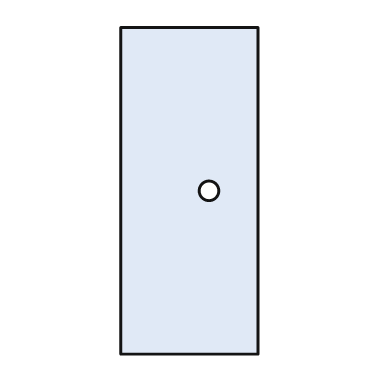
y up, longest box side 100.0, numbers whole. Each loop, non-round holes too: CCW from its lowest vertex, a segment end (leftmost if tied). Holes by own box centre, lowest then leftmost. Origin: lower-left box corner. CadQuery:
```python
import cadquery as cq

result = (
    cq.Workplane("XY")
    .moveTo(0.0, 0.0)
    .lineTo(42.0, 0.0)
    .lineTo(42.0, 100.0)
    .lineTo(0.0, 100.0)
    .close()
    .moveTo(27.0, 50.0)
    .circle(3.0)
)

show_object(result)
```